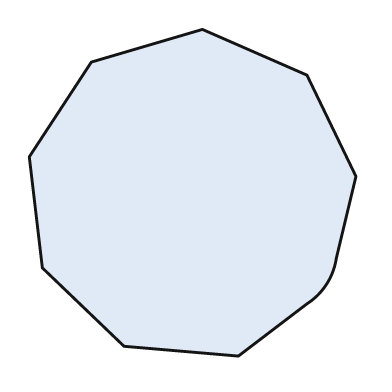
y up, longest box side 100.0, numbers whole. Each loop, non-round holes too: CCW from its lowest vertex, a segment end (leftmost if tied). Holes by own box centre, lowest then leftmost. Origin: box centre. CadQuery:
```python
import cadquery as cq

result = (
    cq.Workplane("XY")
    .moveTo(14.0, -50.0)
    .lineTo(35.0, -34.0)
    .threePointArc((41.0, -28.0), (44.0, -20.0))
    .lineTo(50.0, 5.0)
    .lineTo(35.0, 36.0)
    .lineTo(3.0, 50.0)
    .lineTo(-31.0, 40.0)
    .lineTo(-50.0, 11.0)
    .lineTo(-46.0, -23.0)
    .lineTo(-21.0, -47.0)
    .close()
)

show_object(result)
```